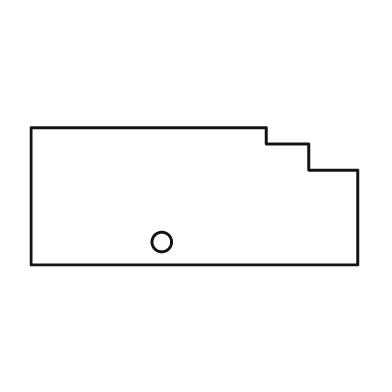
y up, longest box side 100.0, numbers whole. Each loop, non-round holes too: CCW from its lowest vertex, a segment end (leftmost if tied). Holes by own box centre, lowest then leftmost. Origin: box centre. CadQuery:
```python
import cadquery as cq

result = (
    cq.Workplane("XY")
    .moveTo(-50.0, -21.0)
    .lineTo(50.0, -21.0)
    .lineTo(50.0, 8.0)
    .lineTo(35.0, 8.0)
    .lineTo(35.0, 16.0)
    .lineTo(22.0, 16.0)
    .lineTo(22.0, 21.0)
    .lineTo(-50.0, 21.0)
    .close()
    .moveTo(-10.0, -14.0)
    .circle(3.0)
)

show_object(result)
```